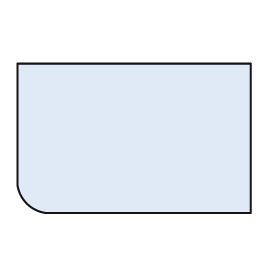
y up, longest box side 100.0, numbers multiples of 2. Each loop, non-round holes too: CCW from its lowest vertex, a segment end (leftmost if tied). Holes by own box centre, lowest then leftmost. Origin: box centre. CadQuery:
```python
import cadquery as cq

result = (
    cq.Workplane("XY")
    .moveTo(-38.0, -32.0)
    .lineTo(50.0, -32.0)
    .lineTo(50.0, 32.0)
    .lineTo(-50.0, 32.0)
    .lineTo(-50.0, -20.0)
    .threePointArc((-46.0, -28.0), (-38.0, -32.0))
    .close()
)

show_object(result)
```